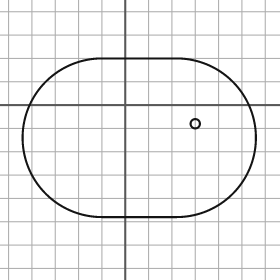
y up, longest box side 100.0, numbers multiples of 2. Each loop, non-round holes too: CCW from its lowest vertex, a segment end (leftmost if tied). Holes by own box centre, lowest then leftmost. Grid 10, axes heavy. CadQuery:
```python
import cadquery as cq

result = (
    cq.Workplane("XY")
    .moveTo(-10.0, -48.0)
    .lineTo(22.0, -48.0)
    .threePointArc((56.0, -14.0), (22.0, 20.0))
    .lineTo(-10.0, 20.0)
    .threePointArc((-44.0, -14.0), (-10.0, -48.0))
    .close()
    .moveTo(30.0, -8.0)
    .circle(2.0)
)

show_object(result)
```